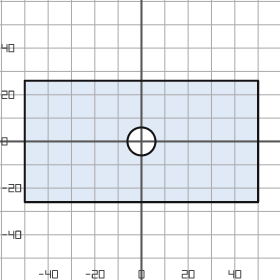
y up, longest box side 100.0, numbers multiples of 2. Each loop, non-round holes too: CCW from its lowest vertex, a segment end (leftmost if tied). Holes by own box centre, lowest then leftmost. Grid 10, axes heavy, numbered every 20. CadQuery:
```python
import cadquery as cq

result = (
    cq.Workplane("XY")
    .moveTo(-50.0, -26.0)
    .lineTo(50.0, -26.0)
    .lineTo(50.0, 26.0)
    .lineTo(-50.0, 26.0)
    .close()
    .moveTo(0.0, 0.0)
    .circle(6.0)
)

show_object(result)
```